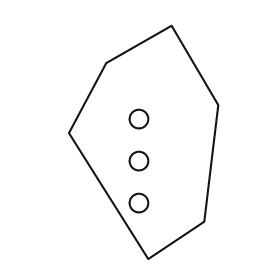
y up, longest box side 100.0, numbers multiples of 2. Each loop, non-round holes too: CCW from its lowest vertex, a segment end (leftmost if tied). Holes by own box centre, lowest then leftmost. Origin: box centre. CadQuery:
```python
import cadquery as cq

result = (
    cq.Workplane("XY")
    .moveTo(2.0, -50.0)
    .lineTo(26.0, -34.0)
    .lineTo(32.0, 16.0)
    .lineTo(12.0, 50.0)
    .lineTo(-16.0, 34.0)
    .lineTo(-32.0, 4.0)
    .close()
    .moveTo(-2.0, -26.0)
    .circle(4.0)
    .moveTo(-2.0, -8.0)
    .circle(4.0)
    .moveTo(-2.0, 10.0)
    .circle(4.0)
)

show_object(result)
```